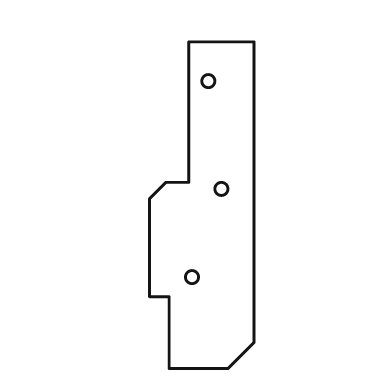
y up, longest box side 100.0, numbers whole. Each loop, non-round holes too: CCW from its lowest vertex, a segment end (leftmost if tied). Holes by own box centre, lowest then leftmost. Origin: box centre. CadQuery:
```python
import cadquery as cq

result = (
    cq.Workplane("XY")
    .moveTo(-10.0, -50.0)
    .lineTo(8.0, -50.0)
    .lineTo(16.0, -42.0)
    .lineTo(16.0, 50.0)
    .lineTo(-4.0, 50.0)
    .lineTo(-4.0, 7.0)
    .lineTo(-11.0, 7.0)
    .lineTo(-16.0, 2.0)
    .lineTo(-16.0, -28.0)
    .lineTo(-10.0, -28.0)
    .close()
    .moveTo(-3.0, -22.0)
    .circle(2.0)
    .moveTo(6.0, 5.0)
    .circle(2.0)
    .moveTo(2.0, 38.0)
    .circle(2.0)
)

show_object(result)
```